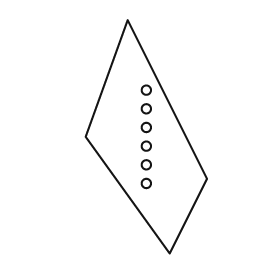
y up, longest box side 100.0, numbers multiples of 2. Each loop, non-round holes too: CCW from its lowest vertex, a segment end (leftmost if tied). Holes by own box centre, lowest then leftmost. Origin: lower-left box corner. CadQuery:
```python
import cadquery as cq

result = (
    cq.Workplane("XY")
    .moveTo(36.0, 0.0)
    .lineTo(52.0, 32.0)
    .lineTo(18.0, 100.0)
    .lineTo(0.0, 50.0)
    .close()
    .moveTo(26.0, 30.0)
    .circle(2.0)
    .moveTo(26.0, 38.0)
    .circle(2.0)
    .moveTo(26.0, 46.0)
    .circle(2.0)
    .moveTo(26.0, 54.0)
    .circle(2.0)
    .moveTo(26.0, 62.0)
    .circle(2.0)
    .moveTo(26.0, 70.0)
    .circle(2.0)
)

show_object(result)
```